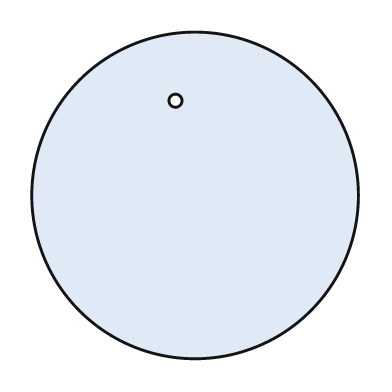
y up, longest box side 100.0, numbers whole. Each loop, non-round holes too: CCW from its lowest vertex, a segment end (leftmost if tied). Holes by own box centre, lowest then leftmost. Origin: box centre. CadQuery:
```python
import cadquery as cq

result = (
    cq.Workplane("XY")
    .moveTo(0.0, 0.0)
    .circle(50.0)
    .moveTo(-6.0, 29.0)
    .circle(2.0)
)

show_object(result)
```